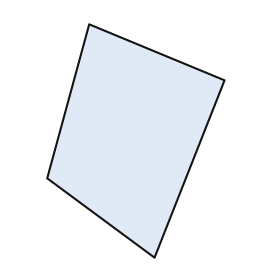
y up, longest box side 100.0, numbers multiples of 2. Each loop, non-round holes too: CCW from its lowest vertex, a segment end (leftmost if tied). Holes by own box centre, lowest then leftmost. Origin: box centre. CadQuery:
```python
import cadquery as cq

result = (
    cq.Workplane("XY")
    .moveTo(8.0, -50.0)
    .lineTo(38.0, 26.0)
    .lineTo(-20.0, 50.0)
    .lineTo(-38.0, -16.0)
    .close()
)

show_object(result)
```